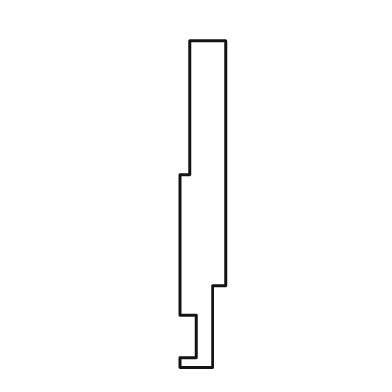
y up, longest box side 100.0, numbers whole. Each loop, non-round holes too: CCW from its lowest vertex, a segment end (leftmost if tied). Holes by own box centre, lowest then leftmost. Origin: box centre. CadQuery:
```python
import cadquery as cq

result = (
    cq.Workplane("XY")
    .moveTo(-7.0, -50.0)
    .lineTo(3.0, -50.0)
    .lineTo(3.0, -25.0)
    .lineTo(7.0, -25.0)
    .lineTo(7.0, 50.0)
    .lineTo(-4.0, 50.0)
    .lineTo(-4.0, 9.0)
    .lineTo(-7.0, 9.0)
    .lineTo(-7.0, -34.0)
    .lineTo(-2.0, -34.0)
    .lineTo(-2.0, -47.0)
    .lineTo(-7.0, -47.0)
    .close()
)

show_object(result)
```